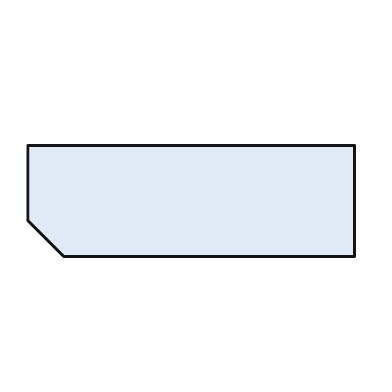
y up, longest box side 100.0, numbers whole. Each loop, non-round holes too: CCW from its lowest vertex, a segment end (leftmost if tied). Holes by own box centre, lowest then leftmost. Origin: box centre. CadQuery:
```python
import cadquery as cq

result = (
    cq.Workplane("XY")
    .moveTo(-39.0, -17.0)
    .lineTo(50.0, -17.0)
    .lineTo(50.0, 17.0)
    .lineTo(-50.0, 17.0)
    .lineTo(-50.0, -6.0)
    .close()
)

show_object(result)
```